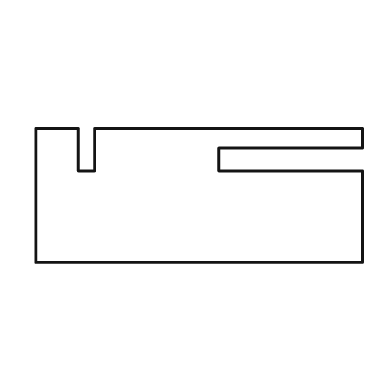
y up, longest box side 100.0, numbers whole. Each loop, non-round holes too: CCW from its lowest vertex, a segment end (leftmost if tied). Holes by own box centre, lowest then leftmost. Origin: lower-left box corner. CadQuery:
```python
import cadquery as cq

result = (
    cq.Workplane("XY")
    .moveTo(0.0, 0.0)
    .lineTo(100.0, 0.0)
    .lineTo(100.0, 28.0)
    .lineTo(56.0, 28.0)
    .lineTo(56.0, 35.0)
    .lineTo(100.0, 35.0)
    .lineTo(100.0, 41.0)
    .lineTo(18.0, 41.0)
    .lineTo(18.0, 28.0)
    .lineTo(13.0, 28.0)
    .lineTo(13.0, 41.0)
    .lineTo(0.0, 41.0)
    .close()
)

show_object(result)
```